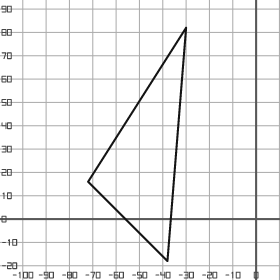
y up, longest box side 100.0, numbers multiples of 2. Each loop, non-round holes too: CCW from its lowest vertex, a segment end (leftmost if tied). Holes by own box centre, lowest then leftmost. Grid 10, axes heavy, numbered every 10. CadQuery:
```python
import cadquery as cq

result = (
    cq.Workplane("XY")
    .moveTo(-38.0, -18.0)
    .lineTo(-30.0, 82.0)
    .lineTo(-72.0, 16.0)
    .close()
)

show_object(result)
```